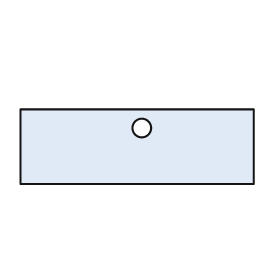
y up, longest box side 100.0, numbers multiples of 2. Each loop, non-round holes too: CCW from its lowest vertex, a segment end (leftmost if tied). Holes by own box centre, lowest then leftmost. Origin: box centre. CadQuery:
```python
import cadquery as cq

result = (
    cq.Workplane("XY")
    .moveTo(-50.0, -16.0)
    .lineTo(50.0, -16.0)
    .lineTo(50.0, 16.0)
    .lineTo(-50.0, 16.0)
    .close()
    .moveTo(2.0, 8.0)
    .circle(4.0)
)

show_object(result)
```